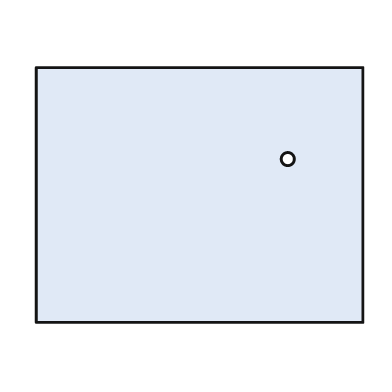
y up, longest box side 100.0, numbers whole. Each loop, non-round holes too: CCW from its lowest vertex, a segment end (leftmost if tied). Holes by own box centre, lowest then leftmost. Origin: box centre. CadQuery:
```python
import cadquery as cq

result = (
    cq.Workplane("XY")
    .moveTo(-50.0, -39.0)
    .lineTo(50.0, -39.0)
    .lineTo(50.0, 39.0)
    .lineTo(-50.0, 39.0)
    .close()
    .moveTo(27.0, 11.0)
    .circle(2.0)
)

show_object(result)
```